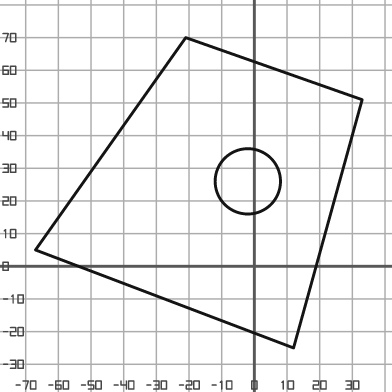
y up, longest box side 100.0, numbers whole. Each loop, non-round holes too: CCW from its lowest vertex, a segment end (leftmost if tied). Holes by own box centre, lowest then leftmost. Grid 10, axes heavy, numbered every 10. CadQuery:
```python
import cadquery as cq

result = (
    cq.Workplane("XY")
    .moveTo(12.0, -25.0)
    .lineTo(33.0, 51.0)
    .lineTo(-21.0, 70.0)
    .lineTo(-67.0, 5.0)
    .close()
    .moveTo(-2.0, 26.0)
    .circle(10.0)
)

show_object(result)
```